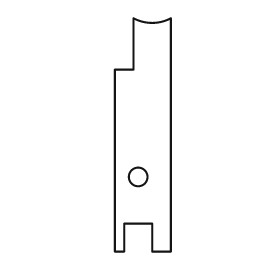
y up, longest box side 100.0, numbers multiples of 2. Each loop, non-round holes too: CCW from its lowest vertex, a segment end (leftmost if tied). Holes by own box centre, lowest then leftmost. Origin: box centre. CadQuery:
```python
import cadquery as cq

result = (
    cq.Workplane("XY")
    .moveTo(-12.0, -50.0)
    .lineTo(-8.0, -50.0)
    .lineTo(-8.0, -38.0)
    .lineTo(4.0, -38.0)
    .lineTo(4.0, -50.0)
    .lineTo(12.0, -50.0)
    .lineTo(12.0, 50.0)
    .threePointArc((4.0, 48.0), (-4.0, 50.0))
    .lineTo(-4.0, 28.0)
    .lineTo(-12.0, 28.0)
    .close()
    .moveTo(-2.0, -18.0)
    .circle(4.0)
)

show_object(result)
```